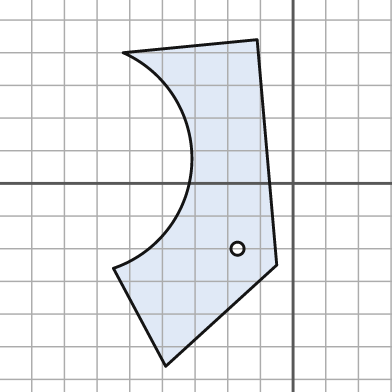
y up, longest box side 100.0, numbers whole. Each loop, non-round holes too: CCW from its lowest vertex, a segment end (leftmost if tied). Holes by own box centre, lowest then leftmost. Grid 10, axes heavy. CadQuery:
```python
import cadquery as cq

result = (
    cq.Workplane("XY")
    .moveTo(-39.0, -56.0)
    .lineTo(-5.0, -25.0)
    .lineTo(-11.0, 44.0)
    .lineTo(-52.0, 40.0)
    .threePointArc((-31.0, 6.0), (-55.0, -26.0))
    .close()
    .moveTo(-17.0, -20.0)
    .circle(2.0)
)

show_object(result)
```